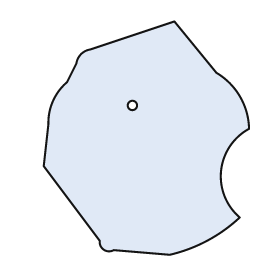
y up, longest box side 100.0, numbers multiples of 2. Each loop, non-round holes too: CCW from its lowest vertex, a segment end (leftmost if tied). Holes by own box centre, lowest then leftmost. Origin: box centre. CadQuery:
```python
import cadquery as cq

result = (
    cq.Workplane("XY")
    .moveTo(10.0, -50.0)
    .threePointArc((26.0, -44.0), (40.0, -34.0))
    .threePointArc((32.0, -14.0), (44.0, 4.0))
    .threePointArc((40.0, 18.0), (30.0, 28.0))
    .lineTo(12.0, 50.0)
    .lineTo(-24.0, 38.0)
    .threePointArc((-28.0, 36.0), (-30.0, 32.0))
    .lineTo(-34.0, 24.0)
    .threePointArc((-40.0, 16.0), (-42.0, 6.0))
    .lineTo(-44.0, -12.0)
    .lineTo(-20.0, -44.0)
    .threePointArc((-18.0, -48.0), (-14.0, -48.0))
    .close()
    .moveTo(-6.0, 14.0)
    .circle(2.0)
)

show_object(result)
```